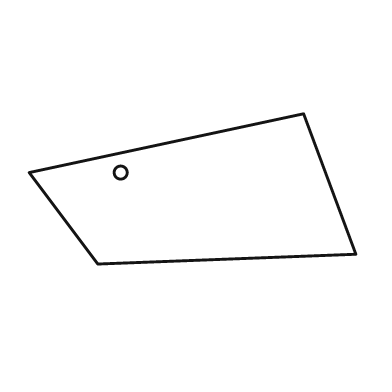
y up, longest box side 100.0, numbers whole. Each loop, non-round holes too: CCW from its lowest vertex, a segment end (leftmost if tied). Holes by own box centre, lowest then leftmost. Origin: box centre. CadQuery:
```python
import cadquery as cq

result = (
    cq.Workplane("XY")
    .moveTo(-29.0, -23.0)
    .lineTo(50.0, -20.0)
    .lineTo(34.0, 23.0)
    .lineTo(-50.0, 5.0)
    .close()
    .moveTo(-22.0, 5.0)
    .circle(2.0)
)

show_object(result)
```